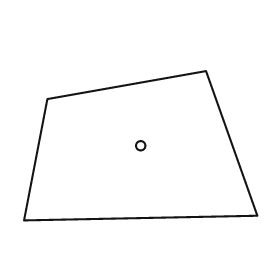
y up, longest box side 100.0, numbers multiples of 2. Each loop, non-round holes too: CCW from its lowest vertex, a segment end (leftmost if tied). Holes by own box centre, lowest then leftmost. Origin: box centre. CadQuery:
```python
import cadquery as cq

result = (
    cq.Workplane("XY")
    .moveTo(-50.0, -32.0)
    .lineTo(50.0, -30.0)
    .lineTo(28.0, 32.0)
    .lineTo(-40.0, 20.0)
    .close()
    .moveTo(0.0, 0.0)
    .circle(2.0)
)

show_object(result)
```